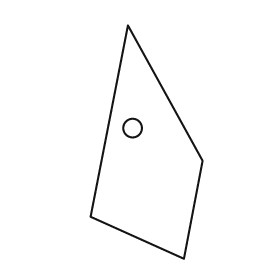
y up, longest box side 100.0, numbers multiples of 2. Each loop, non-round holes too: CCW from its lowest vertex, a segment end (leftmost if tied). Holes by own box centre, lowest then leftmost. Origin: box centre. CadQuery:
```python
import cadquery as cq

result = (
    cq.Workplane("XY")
    .moveTo(16.0, -50.0)
    .lineTo(24.0, -8.0)
    .lineTo(-8.0, 50.0)
    .lineTo(-24.0, -32.0)
    .close()
    .moveTo(-6.0, 6.0)
    .circle(4.0)
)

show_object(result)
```